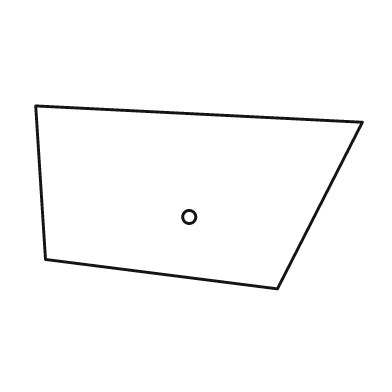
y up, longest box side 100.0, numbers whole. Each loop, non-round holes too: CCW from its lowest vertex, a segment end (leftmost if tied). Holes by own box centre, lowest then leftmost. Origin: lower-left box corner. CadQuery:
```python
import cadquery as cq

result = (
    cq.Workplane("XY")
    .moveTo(74.0, 0.0)
    .lineTo(100.0, 51.0)
    .lineTo(0.0, 56.0)
    .lineTo(3.0, 9.0)
    .close()
    .moveTo(47.0, 22.0)
    .circle(2.0)
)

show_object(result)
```